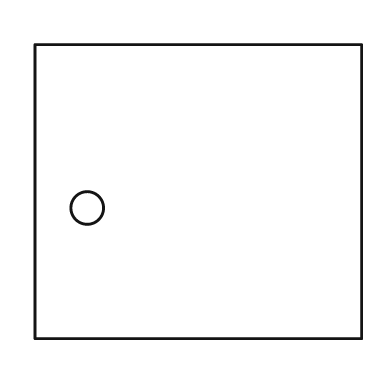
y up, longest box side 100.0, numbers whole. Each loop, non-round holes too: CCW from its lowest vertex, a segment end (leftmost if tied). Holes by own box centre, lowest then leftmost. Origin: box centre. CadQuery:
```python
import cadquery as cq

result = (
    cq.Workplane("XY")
    .moveTo(-50.0, -45.0)
    .lineTo(50.0, -45.0)
    .lineTo(50.0, 45.0)
    .lineTo(-50.0, 45.0)
    .close()
    .moveTo(-34.0, -5.0)
    .circle(5.0)
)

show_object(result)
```